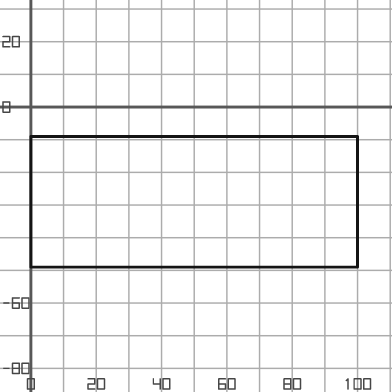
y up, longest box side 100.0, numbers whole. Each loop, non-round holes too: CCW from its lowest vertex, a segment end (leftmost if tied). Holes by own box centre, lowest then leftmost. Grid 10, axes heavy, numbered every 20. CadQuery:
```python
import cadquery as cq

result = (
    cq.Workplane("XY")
    .moveTo(0.0, -49.0)
    .lineTo(100.0, -49.0)
    .lineTo(100.0, -9.0)
    .lineTo(0.0, -9.0)
    .close()
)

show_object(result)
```